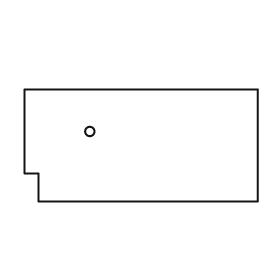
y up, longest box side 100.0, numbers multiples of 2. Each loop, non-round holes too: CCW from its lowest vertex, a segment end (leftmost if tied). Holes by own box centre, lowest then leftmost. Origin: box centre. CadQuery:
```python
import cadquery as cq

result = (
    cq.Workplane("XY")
    .moveTo(-44.0, -24.0)
    .lineTo(50.0, -24.0)
    .lineTo(50.0, 24.0)
    .lineTo(-50.0, 24.0)
    .lineTo(-50.0, -12.0)
    .lineTo(-44.0, -12.0)
    .close()
    .moveTo(-22.0, 6.0)
    .circle(2.0)
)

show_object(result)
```